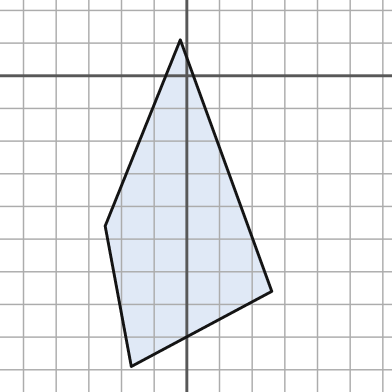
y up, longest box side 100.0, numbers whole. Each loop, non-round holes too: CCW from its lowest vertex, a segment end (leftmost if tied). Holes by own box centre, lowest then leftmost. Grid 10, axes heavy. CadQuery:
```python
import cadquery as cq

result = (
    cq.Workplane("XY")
    .moveTo(-17.0, -89.0)
    .lineTo(26.0, -66.0)
    .lineTo(-2.0, 11.0)
    .lineTo(-25.0, -46.0)
    .close()
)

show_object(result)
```